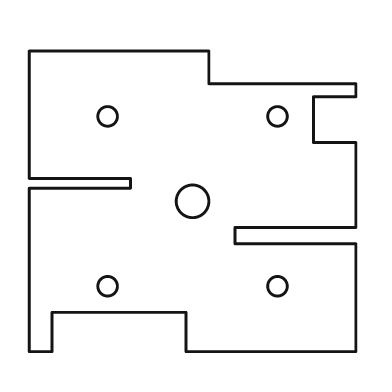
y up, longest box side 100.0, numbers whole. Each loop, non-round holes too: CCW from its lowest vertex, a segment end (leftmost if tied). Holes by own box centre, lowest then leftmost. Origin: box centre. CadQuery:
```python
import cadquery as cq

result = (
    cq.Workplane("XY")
    .moveTo(-50.0, -46.0)
    .lineTo(-43.0, -46.0)
    .lineTo(-43.0, -34.0)
    .lineTo(-2.0, -34.0)
    .lineTo(-2.0, -46.0)
    .lineTo(50.0, -46.0)
    .lineTo(50.0, -13.0)
    .lineTo(13.0, -13.0)
    .lineTo(13.0, -8.0)
    .lineTo(50.0, -8.0)
    .lineTo(50.0, 18.0)
    .lineTo(37.0, 18.0)
    .lineTo(37.0, 32.0)
    .lineTo(50.0, 32.0)
    .lineTo(50.0, 36.0)
    .lineTo(5.0, 36.0)
    .lineTo(5.0, 46.0)
    .lineTo(-50.0, 46.0)
    .lineTo(-50.0, 7.0)
    .lineTo(-19.0, 7.0)
    .lineTo(-19.0, 4.0)
    .lineTo(-50.0, 4.0)
    .close()
    .moveTo(-26.0, -26.0)
    .circle(3.0)
    .moveTo(26.0, -26.0)
    .circle(3.0)
    .moveTo(0.0, 0.0)
    .circle(5.0)
    .moveTo(-26.0, 26.0)
    .circle(3.0)
    .moveTo(26.0, 26.0)
    .circle(3.0)
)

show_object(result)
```